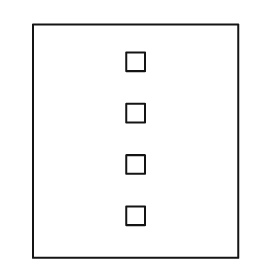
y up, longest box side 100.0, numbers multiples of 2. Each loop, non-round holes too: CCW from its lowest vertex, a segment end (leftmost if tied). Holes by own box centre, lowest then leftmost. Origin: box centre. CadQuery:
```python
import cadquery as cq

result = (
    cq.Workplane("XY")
    .moveTo(-44.0, -50.0)
    .lineTo(44.0, -50.0)
    .lineTo(44.0, 50.0)
    .lineTo(-44.0, 50.0)
    .close()
    .moveTo(-4.0, -36.0)
    .lineTo(4.0, -36.0)
    .lineTo(4.0, -28.0)
    .lineTo(-4.0, -28.0)
    .close()
    .moveTo(-4.0, -14.0)
    .lineTo(4.0, -14.0)
    .lineTo(4.0, -6.0)
    .lineTo(-4.0, -6.0)
    .close()
    .moveTo(-4.0, 8.0)
    .lineTo(4.0, 8.0)
    .lineTo(4.0, 16.0)
    .lineTo(-4.0, 16.0)
    .close()
    .moveTo(-4.0, 30.0)
    .lineTo(4.0, 30.0)
    .lineTo(4.0, 38.0)
    .lineTo(-4.0, 38.0)
    .close()
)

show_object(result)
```